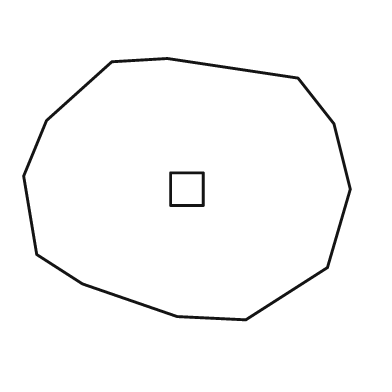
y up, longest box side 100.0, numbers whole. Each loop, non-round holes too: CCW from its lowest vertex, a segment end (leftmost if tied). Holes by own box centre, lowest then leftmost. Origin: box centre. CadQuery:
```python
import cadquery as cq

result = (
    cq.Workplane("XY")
    .moveTo(18.0, -40.0)
    .lineTo(43.0, -24.0)
    .lineTo(50.0, 0.0)
    .lineTo(45.0, 20.0)
    .lineTo(34.0, 34.0)
    .lineTo(-6.0, 40.0)
    .lineTo(-23.0, 39.0)
    .lineTo(-43.0, 21.0)
    .lineTo(-50.0, 4.0)
    .lineTo(-46.0, -20.0)
    .lineTo(-32.0, -29.0)
    .lineTo(-3.0, -39.0)
    .close()
    .moveTo(-5.0, -5.0)
    .lineTo(5.0, -5.0)
    .lineTo(5.0, 5.0)
    .lineTo(-5.0, 5.0)
    .close()
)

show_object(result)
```